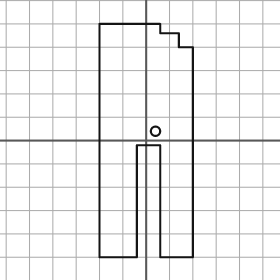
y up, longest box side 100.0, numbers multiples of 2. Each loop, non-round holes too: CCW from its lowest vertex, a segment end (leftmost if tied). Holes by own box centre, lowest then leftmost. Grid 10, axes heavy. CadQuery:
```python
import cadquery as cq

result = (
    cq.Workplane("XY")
    .moveTo(-20.0, -50.0)
    .lineTo(-4.0, -50.0)
    .lineTo(-4.0, -2.0)
    .lineTo(6.0, -2.0)
    .lineTo(6.0, -50.0)
    .lineTo(20.0, -50.0)
    .lineTo(20.0, 40.0)
    .lineTo(14.0, 40.0)
    .lineTo(14.0, 46.0)
    .lineTo(6.0, 46.0)
    .lineTo(6.0, 50.0)
    .lineTo(-20.0, 50.0)
    .close()
    .moveTo(4.0, 4.0)
    .circle(2.0)
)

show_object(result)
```